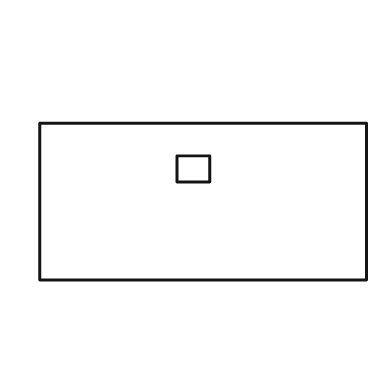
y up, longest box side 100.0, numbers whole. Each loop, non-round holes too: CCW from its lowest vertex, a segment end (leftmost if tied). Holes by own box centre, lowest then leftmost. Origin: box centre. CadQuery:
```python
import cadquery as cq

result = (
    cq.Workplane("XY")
    .moveTo(-50.0, -24.0)
    .lineTo(50.0, -24.0)
    .lineTo(50.0, 24.0)
    .lineTo(-50.0, 24.0)
    .close()
    .moveTo(-8.0, 6.0)
    .lineTo(2.0, 6.0)
    .lineTo(2.0, 14.0)
    .lineTo(-8.0, 14.0)
    .close()
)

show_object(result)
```